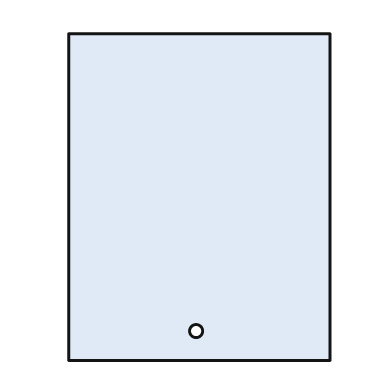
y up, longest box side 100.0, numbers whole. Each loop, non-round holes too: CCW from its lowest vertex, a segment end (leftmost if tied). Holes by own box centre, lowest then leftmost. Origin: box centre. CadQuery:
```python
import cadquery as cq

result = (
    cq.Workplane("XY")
    .moveTo(-40.0, -50.0)
    .lineTo(40.0, -50.0)
    .lineTo(40.0, 50.0)
    .lineTo(-40.0, 50.0)
    .close()
    .moveTo(-1.0, -41.0)
    .circle(2.0)
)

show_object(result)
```